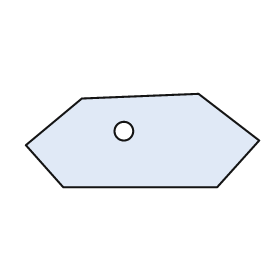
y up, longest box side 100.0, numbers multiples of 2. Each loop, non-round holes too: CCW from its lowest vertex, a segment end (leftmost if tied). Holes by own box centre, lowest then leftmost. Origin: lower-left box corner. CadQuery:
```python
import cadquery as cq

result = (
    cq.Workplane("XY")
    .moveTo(16.0, 0.0)
    .lineTo(82.0, 0.0)
    .lineTo(100.0, 20.0)
    .lineTo(74.0, 40.0)
    .lineTo(24.0, 38.0)
    .lineTo(0.0, 18.0)
    .close()
    .moveTo(42.0, 24.0)
    .circle(4.0)
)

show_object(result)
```